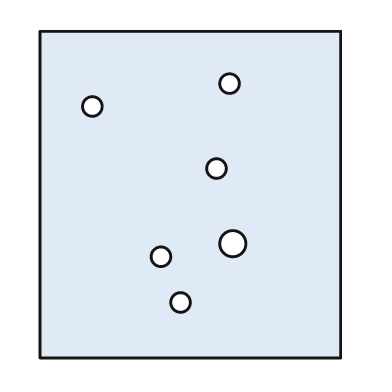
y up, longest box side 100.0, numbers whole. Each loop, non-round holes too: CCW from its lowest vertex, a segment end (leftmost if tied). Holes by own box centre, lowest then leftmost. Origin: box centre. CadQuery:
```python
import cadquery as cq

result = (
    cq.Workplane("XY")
    .moveTo(-46.0, -50.0)
    .lineTo(46.0, -50.0)
    .lineTo(46.0, 50.0)
    .lineTo(-46.0, 50.0)
    .close()
    .moveTo(-3.0, -33.0)
    .circle(3.0)
    .moveTo(-9.0, -19.0)
    .circle(3.0)
    .moveTo(13.0, -15.0)
    .circle(4.0)
    .moveTo(8.0, 8.0)
    .circle(3.0)
    .moveTo(-30.0, 27.0)
    .circle(3.0)
    .moveTo(12.0, 34.0)
    .circle(3.0)
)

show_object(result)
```